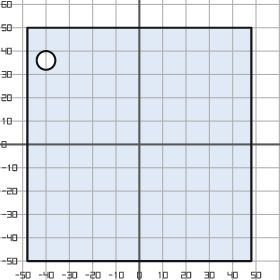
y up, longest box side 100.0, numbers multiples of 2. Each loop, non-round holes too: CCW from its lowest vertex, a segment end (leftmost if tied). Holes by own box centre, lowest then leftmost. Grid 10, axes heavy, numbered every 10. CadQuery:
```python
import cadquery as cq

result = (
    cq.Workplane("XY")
    .moveTo(-48.0, -50.0)
    .lineTo(48.0, -50.0)
    .lineTo(48.0, 50.0)
    .lineTo(-48.0, 50.0)
    .close()
    .moveTo(-40.0, 36.0)
    .circle(4.0)
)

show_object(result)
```